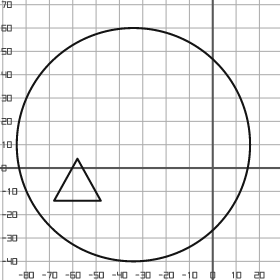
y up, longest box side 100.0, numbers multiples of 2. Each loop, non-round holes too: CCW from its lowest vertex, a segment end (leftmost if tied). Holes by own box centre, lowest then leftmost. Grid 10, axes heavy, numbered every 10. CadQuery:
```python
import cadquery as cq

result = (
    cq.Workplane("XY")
    .moveTo(-34.0, 10.0)
    .circle(50.0)
    .moveTo(-68.0, -14.0)
    .lineTo(-48.0, -14.0)
    .lineTo(-58.0, 4.0)
    .close()
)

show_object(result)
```